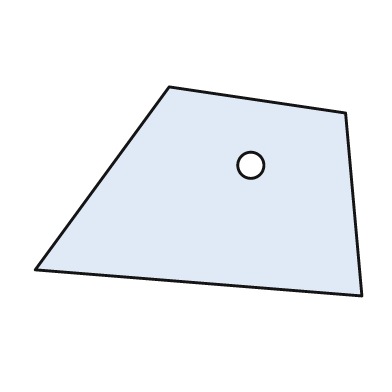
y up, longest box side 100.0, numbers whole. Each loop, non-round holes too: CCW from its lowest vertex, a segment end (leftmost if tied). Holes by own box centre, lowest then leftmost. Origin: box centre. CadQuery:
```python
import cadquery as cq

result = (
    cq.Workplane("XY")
    .moveTo(50.0, -32.0)
    .lineTo(45.0, 24.0)
    .lineTo(-9.0, 32.0)
    .lineTo(-50.0, -24.0)
    .close()
    .moveTo(16.0, 8.0)
    .circle(4.0)
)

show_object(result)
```